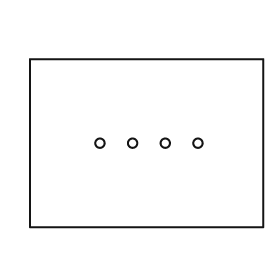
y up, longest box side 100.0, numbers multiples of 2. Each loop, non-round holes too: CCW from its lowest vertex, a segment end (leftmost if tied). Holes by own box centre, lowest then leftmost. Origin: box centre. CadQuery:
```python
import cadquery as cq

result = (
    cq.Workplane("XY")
    .moveTo(-50.0, -36.0)
    .lineTo(50.0, -36.0)
    .lineTo(50.0, 36.0)
    .lineTo(-50.0, 36.0)
    .close()
    .moveTo(-20.0, 0.0)
    .circle(2.0)
    .moveTo(-6.0, 0.0)
    .circle(2.0)
    .moveTo(8.0, 0.0)
    .circle(2.0)
    .moveTo(22.0, 0.0)
    .circle(2.0)
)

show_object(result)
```